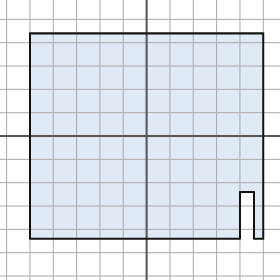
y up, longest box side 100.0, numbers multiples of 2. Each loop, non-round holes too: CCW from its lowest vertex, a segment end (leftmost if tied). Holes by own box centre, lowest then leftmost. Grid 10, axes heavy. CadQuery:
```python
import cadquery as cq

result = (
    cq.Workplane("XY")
    .moveTo(-50.0, -44.0)
    .lineTo(40.0, -44.0)
    .lineTo(40.0, -24.0)
    .lineTo(46.0, -24.0)
    .lineTo(46.0, -44.0)
    .lineTo(50.0, -44.0)
    .lineTo(50.0, 44.0)
    .lineTo(-50.0, 44.0)
    .close()
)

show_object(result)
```